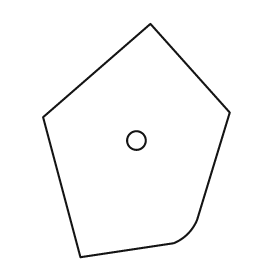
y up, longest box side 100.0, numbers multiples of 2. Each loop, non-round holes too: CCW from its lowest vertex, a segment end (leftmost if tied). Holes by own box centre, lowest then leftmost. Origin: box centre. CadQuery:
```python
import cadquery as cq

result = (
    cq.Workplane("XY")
    .moveTo(-24.0, -50.0)
    .lineTo(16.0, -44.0)
    .threePointArc((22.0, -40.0), (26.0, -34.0))
    .lineTo(40.0, 12.0)
    .lineTo(6.0, 50.0)
    .lineTo(-40.0, 10.0)
    .close()
    .moveTo(0.0, 0.0)
    .circle(4.0)
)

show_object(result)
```